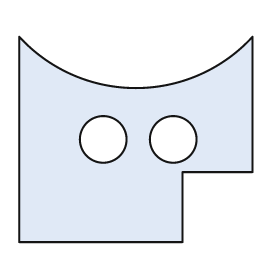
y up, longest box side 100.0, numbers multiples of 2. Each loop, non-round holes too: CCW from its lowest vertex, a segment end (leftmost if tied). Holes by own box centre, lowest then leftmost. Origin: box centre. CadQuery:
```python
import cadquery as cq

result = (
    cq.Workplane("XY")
    .moveTo(-50.0, -44.0)
    .lineTo(20.0, -44.0)
    .lineTo(20.0, -14.0)
    .lineTo(50.0, -14.0)
    .lineTo(50.0, 44.0)
    .threePointArc((0.0, 22.0), (-50.0, 44.0))
    .close()
    .moveTo(-14.0, 0.0)
    .circle(10.0)
    .moveTo(16.0, 0.0)
    .circle(10.0)
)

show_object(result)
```